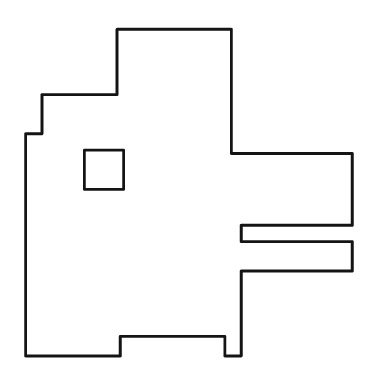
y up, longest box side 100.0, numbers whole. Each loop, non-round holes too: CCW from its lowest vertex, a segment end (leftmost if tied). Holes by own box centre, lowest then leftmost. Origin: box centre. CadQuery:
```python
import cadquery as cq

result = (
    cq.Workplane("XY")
    .moveTo(-50.0, -50.0)
    .lineTo(-21.0, -50.0)
    .lineTo(-21.0, -44.0)
    .lineTo(11.0, -44.0)
    .lineTo(11.0, -50.0)
    .lineTo(16.0, -50.0)
    .lineTo(16.0, -24.0)
    .lineTo(50.0, -24.0)
    .lineTo(50.0, -15.0)
    .lineTo(16.0, -15.0)
    .lineTo(16.0, -10.0)
    .lineTo(50.0, -10.0)
    .lineTo(50.0, 12.0)
    .lineTo(13.0, 12.0)
    .lineTo(13.0, 50.0)
    .lineTo(-22.0, 50.0)
    .lineTo(-22.0, 30.0)
    .lineTo(-45.0, 30.0)
    .lineTo(-45.0, 18.0)
    .lineTo(-50.0, 18.0)
    .close()
    .moveTo(-32.0, 1.0)
    .lineTo(-20.0, 1.0)
    .lineTo(-20.0, 13.0)
    .lineTo(-32.0, 13.0)
    .close()
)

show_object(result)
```